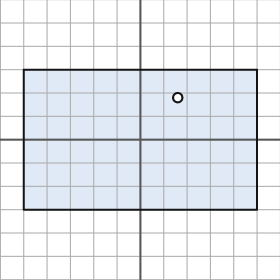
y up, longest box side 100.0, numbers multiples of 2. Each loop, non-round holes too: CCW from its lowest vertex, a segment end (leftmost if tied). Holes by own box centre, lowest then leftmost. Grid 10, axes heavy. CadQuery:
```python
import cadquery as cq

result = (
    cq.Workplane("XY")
    .moveTo(-50.0, -30.0)
    .lineTo(50.0, -30.0)
    .lineTo(50.0, 30.0)
    .lineTo(-50.0, 30.0)
    .close()
    .moveTo(16.0, 18.0)
    .circle(2.0)
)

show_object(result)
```